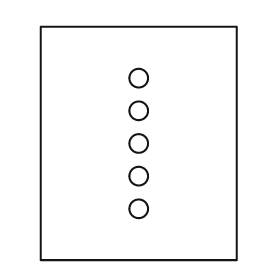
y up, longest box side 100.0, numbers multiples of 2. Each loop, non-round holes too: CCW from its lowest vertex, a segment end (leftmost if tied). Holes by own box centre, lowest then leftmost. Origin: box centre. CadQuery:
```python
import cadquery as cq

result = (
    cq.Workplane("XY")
    .moveTo(-42.0, -50.0)
    .lineTo(42.0, -50.0)
    .lineTo(42.0, 50.0)
    .lineTo(-42.0, 50.0)
    .close()
    .moveTo(0.0, -28.0)
    .circle(4.0)
    .moveTo(0.0, -14.0)
    .circle(4.0)
    .moveTo(0.0, 0.0)
    .circle(4.0)
    .moveTo(0.0, 14.0)
    .circle(4.0)
    .moveTo(0.0, 28.0)
    .circle(4.0)
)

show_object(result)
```